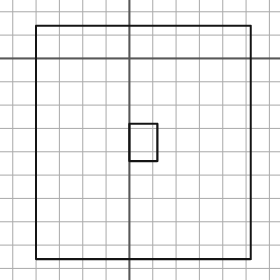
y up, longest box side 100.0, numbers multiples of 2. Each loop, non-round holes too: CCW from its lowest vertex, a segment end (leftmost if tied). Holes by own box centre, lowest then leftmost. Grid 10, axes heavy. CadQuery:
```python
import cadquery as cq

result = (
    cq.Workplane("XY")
    .moveTo(-40.0, -86.0)
    .lineTo(52.0, -86.0)
    .lineTo(52.0, 14.0)
    .lineTo(-40.0, 14.0)
    .close()
    .moveTo(0.0, -44.0)
    .lineTo(12.0, -44.0)
    .lineTo(12.0, -28.0)
    .lineTo(0.0, -28.0)
    .close()
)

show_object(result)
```